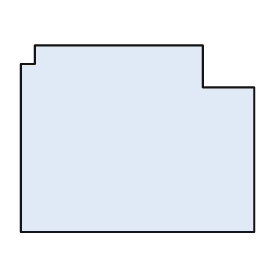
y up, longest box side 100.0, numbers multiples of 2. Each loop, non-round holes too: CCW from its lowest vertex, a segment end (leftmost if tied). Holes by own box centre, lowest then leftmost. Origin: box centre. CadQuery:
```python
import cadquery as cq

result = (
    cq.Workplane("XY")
    .moveTo(-50.0, -40.0)
    .lineTo(50.0, -40.0)
    .lineTo(50.0, 22.0)
    .lineTo(28.0, 22.0)
    .lineTo(28.0, 40.0)
    .lineTo(-44.0, 40.0)
    .lineTo(-44.0, 32.0)
    .lineTo(-50.0, 32.0)
    .close()
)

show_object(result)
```